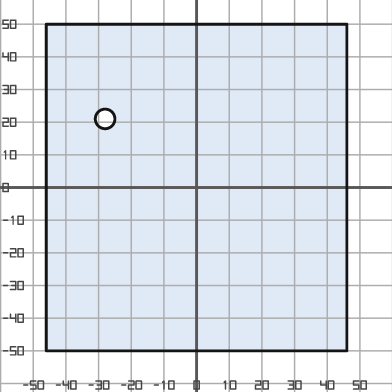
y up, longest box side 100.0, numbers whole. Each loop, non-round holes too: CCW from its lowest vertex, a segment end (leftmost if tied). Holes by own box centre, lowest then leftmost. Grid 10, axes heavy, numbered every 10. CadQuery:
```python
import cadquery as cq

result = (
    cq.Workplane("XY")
    .moveTo(-46.0, -50.0)
    .lineTo(46.0, -50.0)
    .lineTo(46.0, 50.0)
    .lineTo(-46.0, 50.0)
    .close()
    .moveTo(-28.0, 21.0)
    .circle(3.0)
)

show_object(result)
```